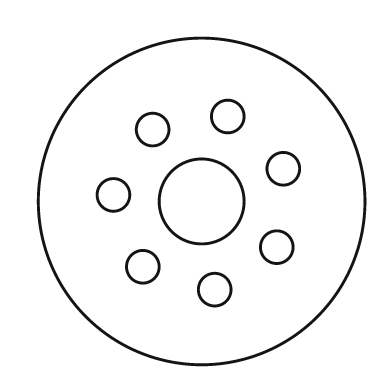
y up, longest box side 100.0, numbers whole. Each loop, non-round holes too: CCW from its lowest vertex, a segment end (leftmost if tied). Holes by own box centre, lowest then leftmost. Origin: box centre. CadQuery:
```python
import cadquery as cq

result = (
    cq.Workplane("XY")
    .moveTo(0.0, 0.0)
    .circle(50.0)
    .moveTo(4.0, -27.0)
    .circle(5.0)
    .moveTo(-18.0, -20.0)
    .circle(5.0)
    .moveTo(23.0, -14.0)
    .circle(5.0)
    .moveTo(0.0, 0.0)
    .circle(13.0)
    .moveTo(-27.0, 2.0)
    .circle(5.0)
    .moveTo(25.0, 10.0)
    .circle(5.0)
    .moveTo(-15.0, 22.0)
    .circle(5.0)
    .moveTo(8.0, 26.0)
    .circle(5.0)
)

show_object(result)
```